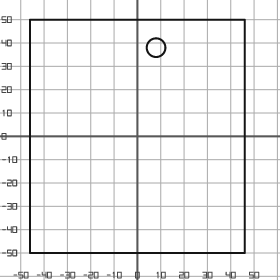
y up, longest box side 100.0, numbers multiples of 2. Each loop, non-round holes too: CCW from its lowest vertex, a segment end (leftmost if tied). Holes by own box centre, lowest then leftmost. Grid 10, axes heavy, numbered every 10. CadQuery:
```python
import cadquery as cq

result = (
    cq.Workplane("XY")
    .moveTo(-46.0, -50.0)
    .lineTo(46.0, -50.0)
    .lineTo(46.0, 50.0)
    .lineTo(-46.0, 50.0)
    .close()
    .moveTo(8.0, 38.0)
    .circle(4.0)
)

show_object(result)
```